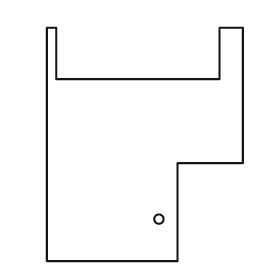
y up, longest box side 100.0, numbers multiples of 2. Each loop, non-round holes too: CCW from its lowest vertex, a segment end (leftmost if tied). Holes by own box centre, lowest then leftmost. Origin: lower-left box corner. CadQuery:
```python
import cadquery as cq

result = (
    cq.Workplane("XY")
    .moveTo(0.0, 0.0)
    .lineTo(56.0, 0.0)
    .lineTo(56.0, 42.0)
    .lineTo(84.0, 42.0)
    .lineTo(84.0, 100.0)
    .lineTo(74.0, 100.0)
    .lineTo(74.0, 78.0)
    .lineTo(4.0, 78.0)
    .lineTo(4.0, 100.0)
    .lineTo(0.0, 100.0)
    .close()
    .moveTo(48.0, 18.0)
    .circle(2.0)
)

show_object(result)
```